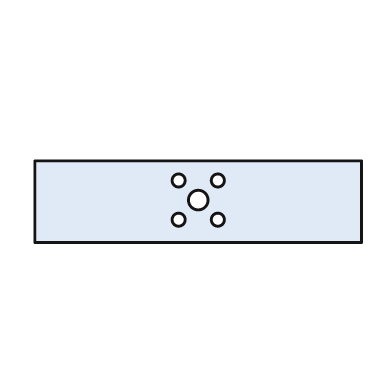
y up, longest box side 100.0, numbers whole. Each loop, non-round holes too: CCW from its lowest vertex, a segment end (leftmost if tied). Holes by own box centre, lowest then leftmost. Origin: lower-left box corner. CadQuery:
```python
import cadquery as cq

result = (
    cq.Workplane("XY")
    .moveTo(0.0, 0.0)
    .lineTo(100.0, 0.0)
    .lineTo(100.0, 25.0)
    .lineTo(0.0, 25.0)
    .close()
    .moveTo(44.0, 7.0)
    .circle(2.0)
    .moveTo(56.0, 7.0)
    .circle(2.0)
    .moveTo(50.0, 13.0)
    .circle(3.0)
    .moveTo(44.0, 19.0)
    .circle(2.0)
    .moveTo(56.0, 19.0)
    .circle(2.0)
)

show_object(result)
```